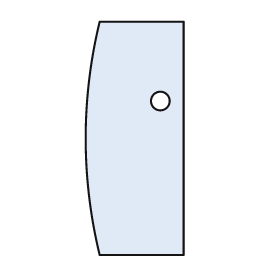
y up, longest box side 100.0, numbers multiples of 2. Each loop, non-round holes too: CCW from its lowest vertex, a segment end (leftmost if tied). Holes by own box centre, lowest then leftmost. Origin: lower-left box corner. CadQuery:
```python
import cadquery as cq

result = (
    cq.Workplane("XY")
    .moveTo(6.0, 0.0)
    .lineTo(42.0, 0.0)
    .lineTo(42.0, 100.0)
    .lineTo(6.0, 100.0)
    .threePointArc((0.0, 50.0), (6.0, 0.0))
    .close()
    .moveTo(32.0, 66.0)
    .circle(4.0)
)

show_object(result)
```